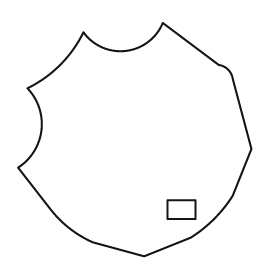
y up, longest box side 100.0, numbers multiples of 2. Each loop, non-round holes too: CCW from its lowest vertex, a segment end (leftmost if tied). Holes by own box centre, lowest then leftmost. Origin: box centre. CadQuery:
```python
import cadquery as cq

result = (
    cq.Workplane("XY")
    .moveTo(4.0, -50.0)
    .lineTo(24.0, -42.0)
    .threePointArc((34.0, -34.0), (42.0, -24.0))
    .lineTo(50.0, -4.0)
    .lineTo(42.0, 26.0)
    .threePointArc((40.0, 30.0), (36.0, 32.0))
    .lineTo(12.0, 50.0)
    .threePointArc((-4.0, 38.0), (-22.0, 46.0))
    .threePointArc((-32.0, 32.0), (-46.0, 22.0))
    .threePointArc((-40.0, 4.0), (-50.0, -12.0))
    .lineTo(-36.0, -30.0)
    .threePointArc((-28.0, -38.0), (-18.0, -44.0))
    .close()
    .moveTo(14.0, -34.0)
    .lineTo(26.0, -34.0)
    .lineTo(26.0, -26.0)
    .lineTo(14.0, -26.0)
    .close()
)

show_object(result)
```